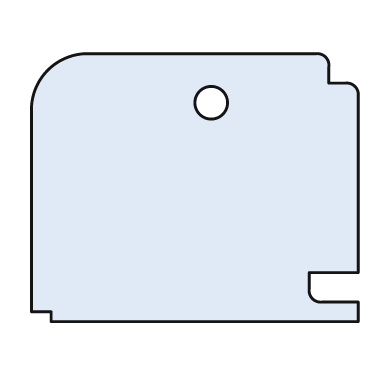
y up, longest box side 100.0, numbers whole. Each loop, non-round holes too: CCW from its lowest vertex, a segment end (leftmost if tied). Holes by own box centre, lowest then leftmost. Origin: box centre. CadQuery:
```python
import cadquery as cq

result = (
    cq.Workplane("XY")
    .moveTo(-44.0, -41.0)
    .lineTo(50.0, -41.0)
    .lineTo(50.0, -35.0)
    .lineTo(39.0, -35.0)
    .threePointArc((36.0, -34.0), (35.0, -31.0))
    .lineTo(35.0, -26.0)
    .lineTo(50.0, -26.0)
    .lineTo(50.0, 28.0)
    .threePointArc((49.0, 31.0), (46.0, 32.0))
    .lineTo(41.0, 32.0)
    .lineTo(41.0, 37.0)
    .threePointArc((40.0, 40.0), (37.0, 41.0))
    .lineTo(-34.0, 41.0)
    .threePointArc((-45.0, 36.0), (-50.0, 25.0))
    .lineTo(-50.0, -38.0)
    .lineTo(-44.0, -38.0)
    .close()
    .moveTo(5.0, 26.0)
    .circle(5.0)
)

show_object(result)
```